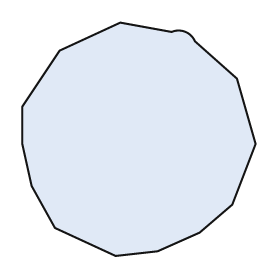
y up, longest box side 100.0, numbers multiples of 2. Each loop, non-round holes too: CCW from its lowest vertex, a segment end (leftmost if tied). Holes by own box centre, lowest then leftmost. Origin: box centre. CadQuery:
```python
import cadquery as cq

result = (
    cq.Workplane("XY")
    .moveTo(-10.0, -50.0)
    .lineTo(8.0, -48.0)
    .lineTo(26.0, -40.0)
    .lineTo(40.0, -28.0)
    .lineTo(50.0, -2.0)
    .lineTo(42.0, 26.0)
    .lineTo(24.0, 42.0)
    .threePointArc((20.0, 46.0), (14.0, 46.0))
    .lineTo(-8.0, 50.0)
    .lineTo(-34.0, 38.0)
    .lineTo(-50.0, 14.0)
    .lineTo(-50.0, -2.0)
    .lineTo(-46.0, -20.0)
    .lineTo(-36.0, -38.0)
    .close()
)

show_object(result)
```